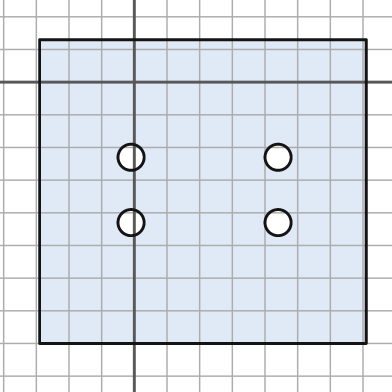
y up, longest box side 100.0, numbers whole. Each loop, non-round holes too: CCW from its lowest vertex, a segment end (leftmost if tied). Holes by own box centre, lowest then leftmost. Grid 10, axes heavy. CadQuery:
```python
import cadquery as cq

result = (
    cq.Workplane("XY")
    .moveTo(-29.0, -80.0)
    .lineTo(71.0, -80.0)
    .lineTo(71.0, 13.0)
    .lineTo(-29.0, 13.0)
    .close()
    .moveTo(-1.0, -43.0)
    .circle(4.0)
    .moveTo(44.0, -43.0)
    .circle(4.0)
    .moveTo(-1.0, -23.0)
    .circle(4.0)
    .moveTo(44.0, -23.0)
    .circle(4.0)
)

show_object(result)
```